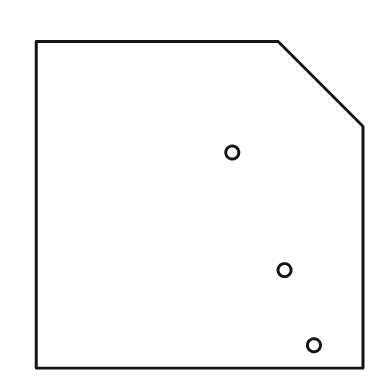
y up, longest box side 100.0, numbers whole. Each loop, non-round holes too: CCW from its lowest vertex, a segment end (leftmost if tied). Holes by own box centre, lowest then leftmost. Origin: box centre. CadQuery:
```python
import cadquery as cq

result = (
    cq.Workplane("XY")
    .moveTo(-50.0, -50.0)
    .lineTo(50.0, -50.0)
    .lineTo(50.0, 24.0)
    .lineTo(24.0, 50.0)
    .lineTo(-50.0, 50.0)
    .close()
    .moveTo(35.0, -43.0)
    .circle(2.0)
    .moveTo(26.0, -20.0)
    .circle(2.0)
    .moveTo(10.0, 16.0)
    .circle(2.0)
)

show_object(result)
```